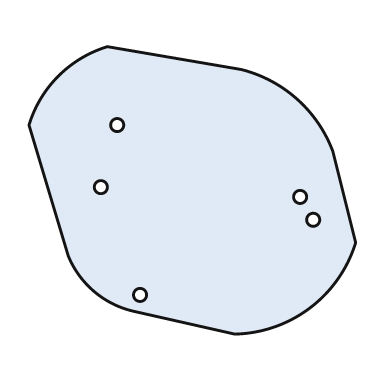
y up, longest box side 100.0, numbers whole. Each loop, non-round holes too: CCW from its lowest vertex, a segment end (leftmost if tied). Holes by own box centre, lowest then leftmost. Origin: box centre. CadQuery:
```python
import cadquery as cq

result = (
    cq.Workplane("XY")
    .moveTo(13.0, -44.0)
    .threePointArc((36.0, -36.0), (50.0, -16.0))
    .lineTo(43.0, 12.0)
    .threePointArc((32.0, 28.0), (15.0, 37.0))
    .lineTo(-26.0, 44.0)
    .threePointArc((-41.0, 35.0), (-50.0, 20.0))
    .lineTo(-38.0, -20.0)
    .threePointArc((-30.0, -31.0), (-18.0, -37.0))
    .close()
    .moveTo(-16.0, -32.0)
    .circle(2.0)
    .moveTo(37.0, -9.0)
    .circle(2.0)
    .moveTo(33.0, -2.0)
    .circle(2.0)
    .moveTo(-28.0, 1.0)
    .circle(2.0)
    .moveTo(-23.0, 20.0)
    .circle(2.0)
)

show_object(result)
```